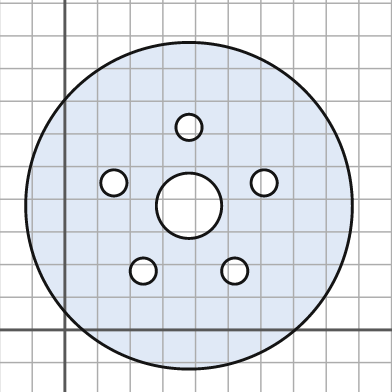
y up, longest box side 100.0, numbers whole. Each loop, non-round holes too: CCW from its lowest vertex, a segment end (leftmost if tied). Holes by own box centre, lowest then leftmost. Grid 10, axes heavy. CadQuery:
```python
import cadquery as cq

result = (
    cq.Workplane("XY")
    .moveTo(38.0, 38.0)
    .circle(50.0)
    .moveTo(24.0, 18.0)
    .circle(4.0)
    .moveTo(52.0, 18.0)
    .circle(4.0)
    .moveTo(38.0, 38.0)
    .circle(10.0)
    .moveTo(15.0, 45.0)
    .circle(4.0)
    .moveTo(61.0, 45.0)
    .circle(4.0)
    .moveTo(38.0, 62.0)
    .circle(4.0)
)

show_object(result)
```